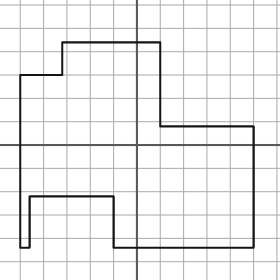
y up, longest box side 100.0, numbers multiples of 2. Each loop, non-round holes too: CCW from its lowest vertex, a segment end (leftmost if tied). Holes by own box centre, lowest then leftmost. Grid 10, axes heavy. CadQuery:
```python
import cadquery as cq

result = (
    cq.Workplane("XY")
    .moveTo(-50.0, -44.0)
    .lineTo(-46.0, -44.0)
    .lineTo(-46.0, -22.0)
    .lineTo(-10.0, -22.0)
    .lineTo(-10.0, -44.0)
    .lineTo(50.0, -44.0)
    .lineTo(50.0, 8.0)
    .lineTo(10.0, 8.0)
    .lineTo(10.0, 44.0)
    .lineTo(-32.0, 44.0)
    .lineTo(-32.0, 30.0)
    .lineTo(-50.0, 30.0)
    .close()
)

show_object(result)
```